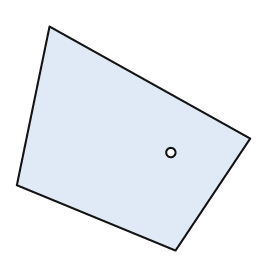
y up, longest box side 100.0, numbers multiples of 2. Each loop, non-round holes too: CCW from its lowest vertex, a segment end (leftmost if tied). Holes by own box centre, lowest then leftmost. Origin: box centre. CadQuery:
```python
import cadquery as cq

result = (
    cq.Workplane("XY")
    .moveTo(18.0, -48.0)
    .lineTo(50.0, 0.0)
    .lineTo(-36.0, 48.0)
    .lineTo(-50.0, -20.0)
    .close()
    .moveTo(16.0, -6.0)
    .circle(2.0)
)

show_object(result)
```